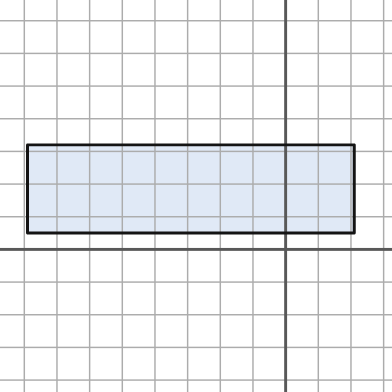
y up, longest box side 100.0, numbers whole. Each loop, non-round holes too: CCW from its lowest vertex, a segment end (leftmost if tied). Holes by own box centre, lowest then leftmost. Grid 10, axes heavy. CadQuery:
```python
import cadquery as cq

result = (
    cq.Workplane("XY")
    .moveTo(-79.0, 5.0)
    .lineTo(21.0, 5.0)
    .lineTo(21.0, 32.0)
    .lineTo(-79.0, 32.0)
    .close()
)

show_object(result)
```